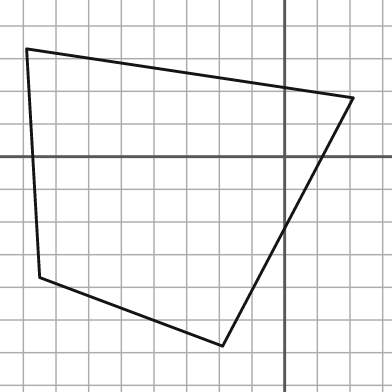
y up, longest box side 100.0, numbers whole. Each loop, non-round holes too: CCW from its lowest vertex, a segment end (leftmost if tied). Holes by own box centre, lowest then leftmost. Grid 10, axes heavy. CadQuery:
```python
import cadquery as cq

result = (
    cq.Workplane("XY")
    .moveTo(-19.0, -58.0)
    .lineTo(21.0, 18.0)
    .lineTo(-79.0, 33.0)
    .lineTo(-75.0, -37.0)
    .close()
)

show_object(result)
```